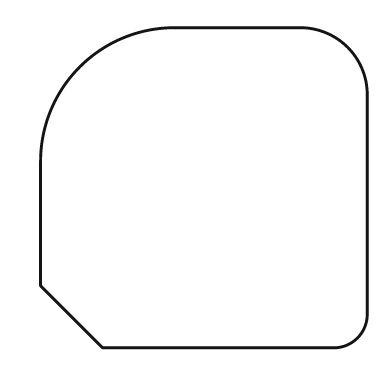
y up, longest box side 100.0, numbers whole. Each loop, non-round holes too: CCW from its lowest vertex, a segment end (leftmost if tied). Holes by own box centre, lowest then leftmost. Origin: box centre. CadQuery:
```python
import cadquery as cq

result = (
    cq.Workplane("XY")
    .moveTo(-31.0, -49.0)
    .lineTo(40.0, -49.0)
    .threePointArc((47.0, -46.0), (50.0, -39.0))
    .lineTo(50.0, 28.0)
    .threePointArc((44.0, 43.0), (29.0, 49.0))
    .lineTo(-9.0, 49.0)
    .threePointArc((-38.0, 37.0), (-50.0, 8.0))
    .lineTo(-50.0, -30.0)
    .close()
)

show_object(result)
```